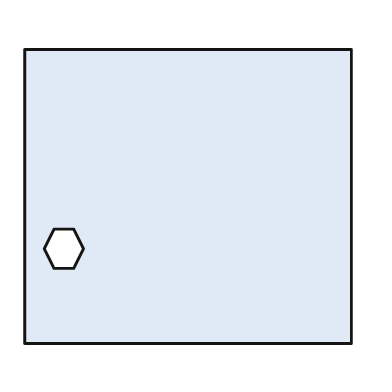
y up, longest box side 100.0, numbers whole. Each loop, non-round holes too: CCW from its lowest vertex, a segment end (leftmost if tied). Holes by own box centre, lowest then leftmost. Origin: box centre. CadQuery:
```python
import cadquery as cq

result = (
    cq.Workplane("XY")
    .moveTo(-50.0, -45.0)
    .lineTo(50.0, -45.0)
    .lineTo(50.0, 45.0)
    .lineTo(-50.0, 45.0)
    .close()
    .moveTo(-41.0, -22.0)
    .lineTo(-35.0, -22.0)
    .lineTo(-32.0, -16.0)
    .lineTo(-35.0, -10.0)
    .lineTo(-41.0, -10.0)
    .lineTo(-44.0, -16.0)
    .close()
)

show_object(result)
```